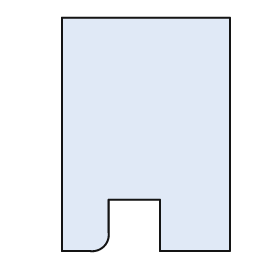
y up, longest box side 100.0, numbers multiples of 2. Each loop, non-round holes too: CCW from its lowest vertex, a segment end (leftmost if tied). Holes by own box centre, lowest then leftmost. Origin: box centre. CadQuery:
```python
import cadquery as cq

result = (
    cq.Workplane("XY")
    .moveTo(-36.0, -50.0)
    .lineTo(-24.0, -50.0)
    .threePointArc((-18.0, -48.0), (-16.0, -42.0))
    .lineTo(-16.0, -28.0)
    .lineTo(6.0, -28.0)
    .lineTo(6.0, -50.0)
    .lineTo(36.0, -50.0)
    .lineTo(36.0, 50.0)
    .lineTo(-36.0, 50.0)
    .close()
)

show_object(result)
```